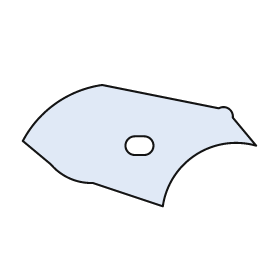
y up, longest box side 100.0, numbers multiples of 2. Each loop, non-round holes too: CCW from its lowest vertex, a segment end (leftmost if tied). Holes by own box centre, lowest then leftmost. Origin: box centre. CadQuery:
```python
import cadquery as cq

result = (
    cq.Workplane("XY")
    .moveTo(10.0, -26.0)
    .threePointArc((24.0, -4.0), (50.0, 0.0))
    .lineTo(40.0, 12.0)
    .threePointArc((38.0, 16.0), (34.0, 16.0))
    .lineTo(-16.0, 26.0)
    .threePointArc((-36.0, 18.0), (-50.0, 2.0))
    .lineTo(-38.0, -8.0)
    .threePointArc((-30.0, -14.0), (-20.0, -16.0))
    .close()
    .moveTo(-2.0, -4.0)
    .lineTo(2.0, -4.0)
    .threePointArc((6.0, 0.0), (2.0, 4.0))
    .lineTo(-2.0, 4.0)
    .threePointArc((-6.0, 0.0), (-2.0, -4.0))
    .close()
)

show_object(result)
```